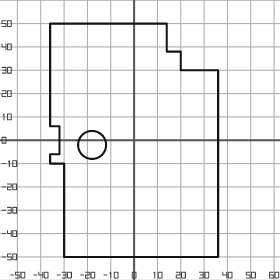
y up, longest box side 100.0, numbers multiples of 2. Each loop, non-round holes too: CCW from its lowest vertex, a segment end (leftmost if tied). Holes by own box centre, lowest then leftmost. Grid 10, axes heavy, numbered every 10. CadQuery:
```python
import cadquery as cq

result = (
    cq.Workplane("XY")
    .moveTo(-30.0, -50.0)
    .lineTo(36.0, -50.0)
    .lineTo(36.0, 30.0)
    .lineTo(20.0, 30.0)
    .lineTo(20.0, 38.0)
    .lineTo(14.0, 38.0)
    .lineTo(14.0, 50.0)
    .lineTo(-36.0, 50.0)
    .lineTo(-36.0, 6.0)
    .lineTo(-32.0, 6.0)
    .lineTo(-32.0, -6.0)
    .lineTo(-36.0, -6.0)
    .lineTo(-36.0, -10.0)
    .lineTo(-30.0, -10.0)
    .close()
    .moveTo(-18.0, -2.0)
    .circle(6.0)
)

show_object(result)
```